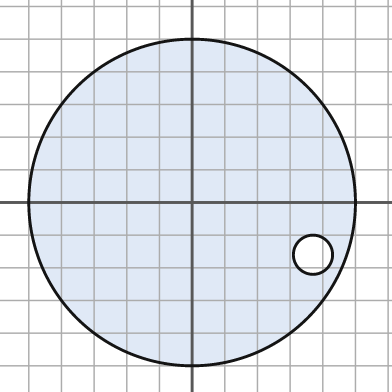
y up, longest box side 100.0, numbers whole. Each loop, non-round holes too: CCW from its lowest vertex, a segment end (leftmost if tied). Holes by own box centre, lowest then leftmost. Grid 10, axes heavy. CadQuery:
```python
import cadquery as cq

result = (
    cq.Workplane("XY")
    .moveTo(0.0, 0.0)
    .circle(50.0)
    .moveTo(37.0, -16.0)
    .circle(6.0)
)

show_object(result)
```